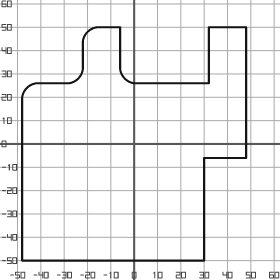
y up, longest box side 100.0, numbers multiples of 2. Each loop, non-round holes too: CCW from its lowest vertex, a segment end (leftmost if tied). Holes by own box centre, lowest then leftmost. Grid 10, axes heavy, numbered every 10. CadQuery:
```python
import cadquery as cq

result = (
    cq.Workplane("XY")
    .moveTo(-48.0, -50.0)
    .lineTo(30.0, -50.0)
    .lineTo(30.0, -6.0)
    .lineTo(48.0, -6.0)
    .lineTo(48.0, 50.0)
    .lineTo(32.0, 50.0)
    .lineTo(32.0, 26.0)
    .lineTo(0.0, 26.0)
    .threePointArc((-4.0, 28.0), (-6.0, 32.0))
    .lineTo(-6.0, 50.0)
    .lineTo(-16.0, 50.0)
    .threePointArc((-20.0, 48.0), (-22.0, 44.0))
    .lineTo(-22.0, 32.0)
    .threePointArc((-24.0, 28.0), (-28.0, 26.0))
    .lineTo(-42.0, 26.0)
    .threePointArc((-46.0, 24.0), (-48.0, 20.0))
    .close()
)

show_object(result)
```